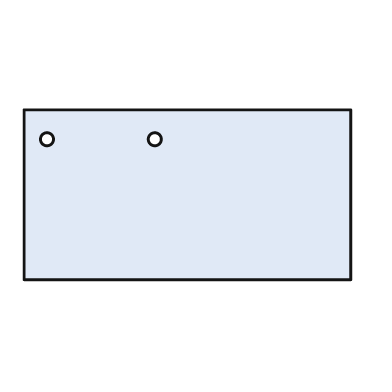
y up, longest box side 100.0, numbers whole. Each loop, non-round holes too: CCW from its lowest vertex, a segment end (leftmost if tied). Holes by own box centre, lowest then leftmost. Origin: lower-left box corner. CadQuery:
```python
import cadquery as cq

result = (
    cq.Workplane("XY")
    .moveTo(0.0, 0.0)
    .lineTo(100.0, 0.0)
    .lineTo(100.0, 52.0)
    .lineTo(0.0, 52.0)
    .close()
    .moveTo(7.0, 43.0)
    .circle(2.0)
    .moveTo(40.0, 43.0)
    .circle(2.0)
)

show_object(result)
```